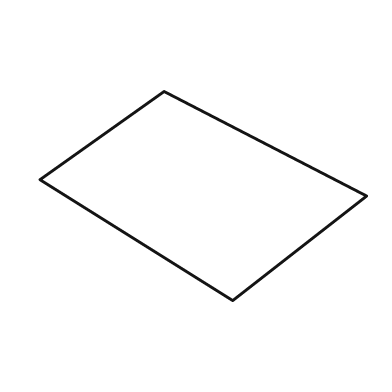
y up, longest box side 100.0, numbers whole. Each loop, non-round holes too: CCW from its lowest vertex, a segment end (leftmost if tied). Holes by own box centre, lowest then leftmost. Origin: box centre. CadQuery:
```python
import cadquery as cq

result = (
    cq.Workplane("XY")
    .moveTo(9.0, -32.0)
    .lineTo(50.0, 0.0)
    .lineTo(-12.0, 32.0)
    .lineTo(-50.0, 5.0)
    .close()
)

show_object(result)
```